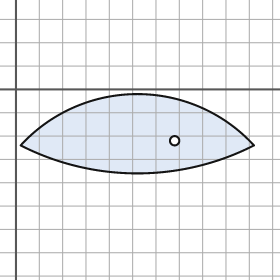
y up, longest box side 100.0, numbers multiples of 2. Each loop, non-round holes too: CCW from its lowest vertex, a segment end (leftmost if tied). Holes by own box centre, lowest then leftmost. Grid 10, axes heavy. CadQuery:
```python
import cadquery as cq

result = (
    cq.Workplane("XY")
    .moveTo(2.0, -24.0)
    .threePointArc((52.0, -36.0), (102.0, -24.0))
    .threePointArc((52.0, -2.0), (2.0, -24.0))
    .close()
    .moveTo(68.0, -22.0)
    .circle(2.0)
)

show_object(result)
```